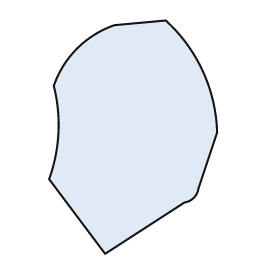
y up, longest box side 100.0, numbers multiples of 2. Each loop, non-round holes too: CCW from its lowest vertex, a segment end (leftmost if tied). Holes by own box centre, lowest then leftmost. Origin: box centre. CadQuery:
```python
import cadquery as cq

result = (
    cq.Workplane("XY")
    .moveTo(-12.0, -50.0)
    .lineTo(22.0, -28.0)
    .threePointArc((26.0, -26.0), (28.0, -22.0))
    .lineTo(36.0, 2.0)
    .threePointArc((30.0, 28.0), (14.0, 50.0))
    .lineTo(-8.0, 48.0)
    .threePointArc((-24.0, 38.0), (-34.0, 22.0))
    .threePointArc((-32.0, 2.0), (-36.0, -18.0))
    .close()
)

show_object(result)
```